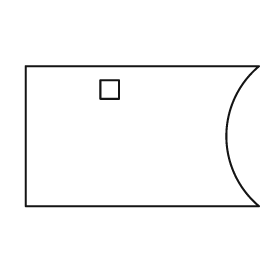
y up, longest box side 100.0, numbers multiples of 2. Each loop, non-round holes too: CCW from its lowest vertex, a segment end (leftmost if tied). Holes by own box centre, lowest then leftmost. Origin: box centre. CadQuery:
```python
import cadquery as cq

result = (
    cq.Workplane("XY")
    .moveTo(-50.0, -30.0)
    .lineTo(50.0, -30.0)
    .threePointArc((36.0, 0.0), (50.0, 30.0))
    .lineTo(-50.0, 30.0)
    .close()
    .moveTo(-18.0, 16.0)
    .lineTo(-10.0, 16.0)
    .lineTo(-10.0, 24.0)
    .lineTo(-18.0, 24.0)
    .close()
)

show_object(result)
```